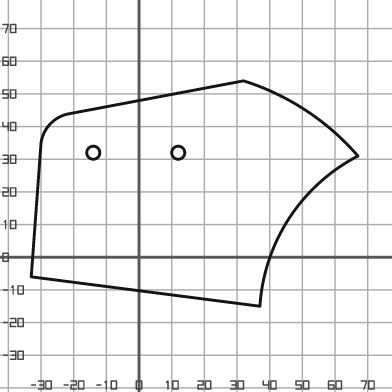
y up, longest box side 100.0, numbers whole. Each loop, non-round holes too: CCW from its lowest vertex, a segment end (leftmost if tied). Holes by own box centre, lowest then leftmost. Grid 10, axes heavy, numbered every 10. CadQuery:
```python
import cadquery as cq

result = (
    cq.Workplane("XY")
    .moveTo(37.0, -15.0)
    .threePointArc((46.0, 12.0), (67.0, 31.0))
    .threePointArc((51.0, 45.0), (32.0, 54.0))
    .lineTo(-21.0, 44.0)
    .threePointArc((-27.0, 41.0), (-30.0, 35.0))
    .lineTo(-33.0, -6.0)
    .close()
    .moveTo(-14.0, 32.0)
    .circle(2.0)
    .moveTo(12.0, 32.0)
    .circle(2.0)
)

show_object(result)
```